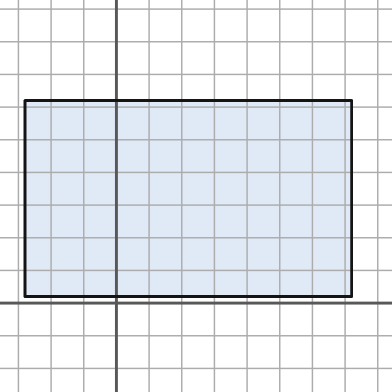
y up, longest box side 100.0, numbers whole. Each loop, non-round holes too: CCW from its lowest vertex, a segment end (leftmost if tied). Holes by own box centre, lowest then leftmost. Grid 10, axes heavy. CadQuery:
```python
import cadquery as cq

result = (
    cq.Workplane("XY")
    .moveTo(-28.0, 2.0)
    .lineTo(72.0, 2.0)
    .lineTo(72.0, 62.0)
    .lineTo(-28.0, 62.0)
    .close()
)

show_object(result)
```